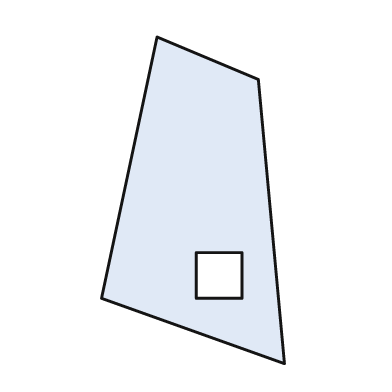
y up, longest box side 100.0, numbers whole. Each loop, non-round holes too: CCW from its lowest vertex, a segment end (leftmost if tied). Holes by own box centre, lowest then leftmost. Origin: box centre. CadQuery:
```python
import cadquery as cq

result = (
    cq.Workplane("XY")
    .moveTo(28.0, -50.0)
    .lineTo(20.0, 37.0)
    .lineTo(-11.0, 50.0)
    .lineTo(-28.0, -30.0)
    .close()
    .moveTo(1.0, -30.0)
    .lineTo(15.0, -30.0)
    .lineTo(15.0, -16.0)
    .lineTo(1.0, -16.0)
    .close()
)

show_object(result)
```